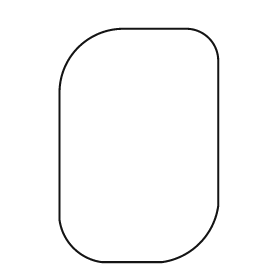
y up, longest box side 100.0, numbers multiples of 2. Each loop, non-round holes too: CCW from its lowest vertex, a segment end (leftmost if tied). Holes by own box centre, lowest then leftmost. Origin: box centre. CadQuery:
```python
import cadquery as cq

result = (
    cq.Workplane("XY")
    .moveTo(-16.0, -50.0)
    .lineTo(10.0, -50.0)
    .threePointArc((26.0, -42.0), (34.0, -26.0))
    .lineTo(34.0, 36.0)
    .threePointArc((30.0, 46.0), (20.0, 50.0))
    .lineTo(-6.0, 50.0)
    .threePointArc((-26.0, 42.0), (-34.0, 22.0))
    .lineTo(-34.0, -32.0)
    .threePointArc((-28.0, -44.0), (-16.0, -50.0))
    .close()
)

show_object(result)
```